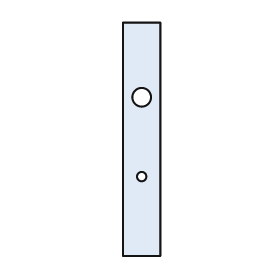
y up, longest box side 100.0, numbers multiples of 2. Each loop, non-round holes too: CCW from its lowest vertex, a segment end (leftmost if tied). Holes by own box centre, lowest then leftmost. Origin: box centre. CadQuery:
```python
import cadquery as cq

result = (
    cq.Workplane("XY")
    .moveTo(-8.0, -50.0)
    .lineTo(8.0, -50.0)
    .lineTo(8.0, 50.0)
    .lineTo(-8.0, 50.0)
    .close()
    .moveTo(0.0, -16.0)
    .circle(2.0)
    .moveTo(0.0, 18.0)
    .circle(4.0)
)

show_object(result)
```